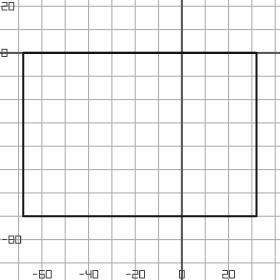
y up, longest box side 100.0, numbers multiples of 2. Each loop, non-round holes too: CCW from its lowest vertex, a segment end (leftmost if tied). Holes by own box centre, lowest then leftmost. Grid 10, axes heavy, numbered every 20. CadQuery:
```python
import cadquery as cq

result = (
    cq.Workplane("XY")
    .moveTo(-68.0, -70.0)
    .lineTo(32.0, -70.0)
    .lineTo(32.0, 0.0)
    .lineTo(-68.0, 0.0)
    .close()
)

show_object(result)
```